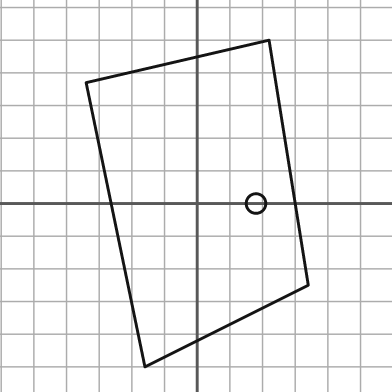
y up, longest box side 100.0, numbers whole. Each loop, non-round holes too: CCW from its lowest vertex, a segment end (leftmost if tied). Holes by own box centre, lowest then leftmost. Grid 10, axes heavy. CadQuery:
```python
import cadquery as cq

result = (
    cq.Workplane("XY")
    .moveTo(-16.0, -50.0)
    .lineTo(34.0, -25.0)
    .lineTo(22.0, 50.0)
    .lineTo(-34.0, 37.0)
    .close()
    .moveTo(18.0, 0.0)
    .circle(3.0)
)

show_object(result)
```